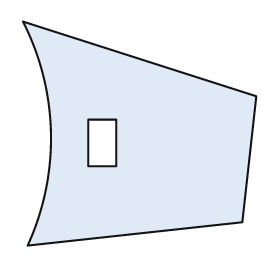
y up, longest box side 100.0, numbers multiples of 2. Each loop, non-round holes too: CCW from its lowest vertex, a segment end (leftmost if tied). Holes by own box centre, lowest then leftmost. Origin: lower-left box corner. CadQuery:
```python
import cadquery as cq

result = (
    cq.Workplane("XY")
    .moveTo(2.0, 0.0)
    .lineTo(94.0, 10.0)
    .lineTo(100.0, 64.0)
    .lineTo(0.0, 96.0)
    .threePointArc((12.0, 48.0), (2.0, 0.0))
    .close()
    .moveTo(28.0, 34.0)
    .lineTo(40.0, 34.0)
    .lineTo(40.0, 54.0)
    .lineTo(28.0, 54.0)
    .close()
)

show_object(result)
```